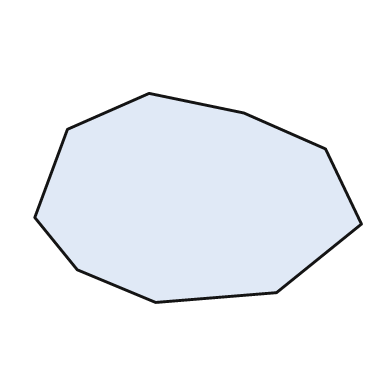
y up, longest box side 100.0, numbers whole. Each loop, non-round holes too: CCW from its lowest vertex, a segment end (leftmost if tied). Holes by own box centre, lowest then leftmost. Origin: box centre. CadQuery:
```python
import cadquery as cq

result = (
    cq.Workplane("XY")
    .moveTo(-13.0, -32.0)
    .lineTo(24.0, -29.0)
    .lineTo(50.0, -8.0)
    .lineTo(39.0, 15.0)
    .lineTo(14.0, 26.0)
    .lineTo(-15.0, 32.0)
    .lineTo(-40.0, 21.0)
    .lineTo(-50.0, -6.0)
    .lineTo(-37.0, -22.0)
    .close()
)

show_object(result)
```